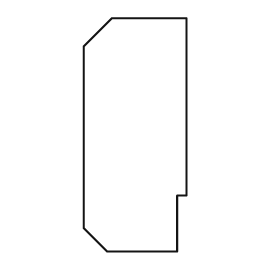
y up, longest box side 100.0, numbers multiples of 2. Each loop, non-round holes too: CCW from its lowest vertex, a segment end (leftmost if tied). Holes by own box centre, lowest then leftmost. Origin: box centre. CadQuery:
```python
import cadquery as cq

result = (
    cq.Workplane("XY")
    .moveTo(-12.0, -50.0)
    .lineTo(18.0, -50.0)
    .lineTo(18.0, -26.0)
    .lineTo(22.0, -26.0)
    .lineTo(22.0, 50.0)
    .lineTo(-10.0, 50.0)
    .lineTo(-22.0, 38.0)
    .lineTo(-22.0, -40.0)
    .close()
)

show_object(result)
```